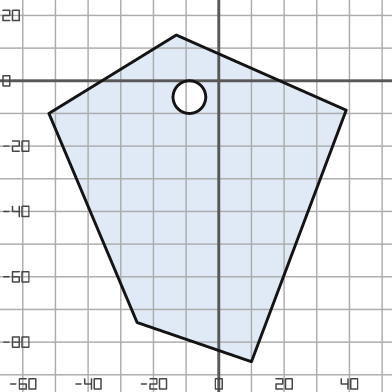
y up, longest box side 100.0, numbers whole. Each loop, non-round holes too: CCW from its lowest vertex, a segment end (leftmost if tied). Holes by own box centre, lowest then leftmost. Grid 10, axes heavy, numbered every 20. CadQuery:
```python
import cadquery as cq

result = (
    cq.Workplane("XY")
    .moveTo(10.0, -86.0)
    .lineTo(39.0, -9.0)
    .lineTo(-13.0, 14.0)
    .lineTo(-52.0, -10.0)
    .lineTo(-25.0, -74.0)
    .close()
    .moveTo(-9.0, -5.0)
    .circle(5.0)
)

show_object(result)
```